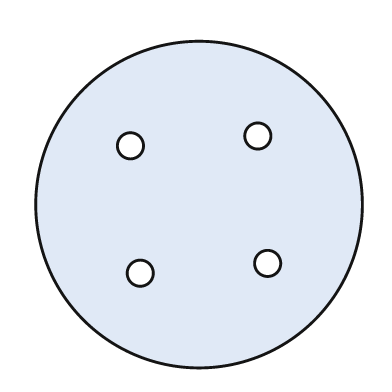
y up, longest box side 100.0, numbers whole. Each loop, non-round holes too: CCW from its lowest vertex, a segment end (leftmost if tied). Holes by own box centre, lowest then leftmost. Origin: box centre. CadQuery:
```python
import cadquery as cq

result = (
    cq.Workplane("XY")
    .moveTo(0.0, 0.0)
    .circle(50.0)
    .moveTo(-18.0, -21.0)
    .circle(4.0)
    .moveTo(21.0, -18.0)
    .circle(4.0)
    .moveTo(-21.0, 18.0)
    .circle(4.0)
    .moveTo(18.0, 21.0)
    .circle(4.0)
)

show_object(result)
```